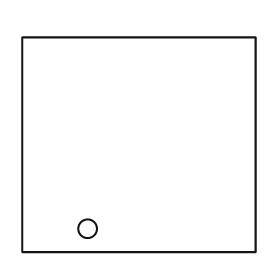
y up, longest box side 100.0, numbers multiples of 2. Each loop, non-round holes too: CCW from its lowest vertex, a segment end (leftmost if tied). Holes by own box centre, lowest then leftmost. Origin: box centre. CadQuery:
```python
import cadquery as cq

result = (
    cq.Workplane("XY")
    .moveTo(-50.0, -46.0)
    .lineTo(50.0, -46.0)
    .lineTo(50.0, 46.0)
    .lineTo(-50.0, 46.0)
    .close()
    .moveTo(-22.0, -36.0)
    .circle(4.0)
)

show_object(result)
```